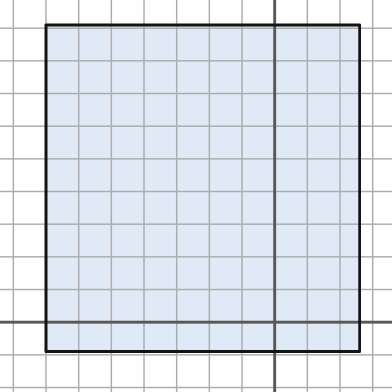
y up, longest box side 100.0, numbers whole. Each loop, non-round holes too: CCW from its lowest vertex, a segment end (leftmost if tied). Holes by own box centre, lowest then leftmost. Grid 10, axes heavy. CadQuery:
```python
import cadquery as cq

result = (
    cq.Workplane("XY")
    .moveTo(-70.0, -9.0)
    .lineTo(26.0, -9.0)
    .lineTo(26.0, 91.0)
    .lineTo(-70.0, 91.0)
    .close()
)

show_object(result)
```